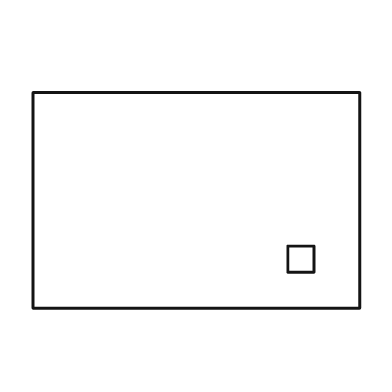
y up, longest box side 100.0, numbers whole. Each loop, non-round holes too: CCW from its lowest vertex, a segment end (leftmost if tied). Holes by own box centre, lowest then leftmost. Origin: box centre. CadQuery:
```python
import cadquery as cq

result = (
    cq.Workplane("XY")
    .moveTo(-50.0, -33.0)
    .lineTo(50.0, -33.0)
    .lineTo(50.0, 33.0)
    .lineTo(-50.0, 33.0)
    .close()
    .moveTo(28.0, -22.0)
    .lineTo(36.0, -22.0)
    .lineTo(36.0, -14.0)
    .lineTo(28.0, -14.0)
    .close()
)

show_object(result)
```